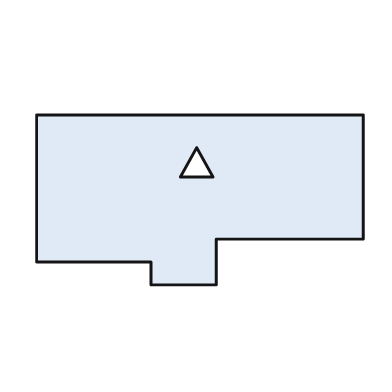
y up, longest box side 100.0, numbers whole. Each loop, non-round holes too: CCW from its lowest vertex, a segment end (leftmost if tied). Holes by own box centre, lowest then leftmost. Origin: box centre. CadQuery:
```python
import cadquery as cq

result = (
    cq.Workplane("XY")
    .moveTo(-15.0, -26.0)
    .lineTo(5.0, -26.0)
    .lineTo(5.0, -12.0)
    .lineTo(50.0, -12.0)
    .lineTo(50.0, 26.0)
    .lineTo(-50.0, 26.0)
    .lineTo(-50.0, -19.0)
    .lineTo(-15.0, -19.0)
    .close()
    .moveTo(-6.0, 7.0)
    .lineTo(4.0, 7.0)
    .lineTo(-1.0, 16.0)
    .close()
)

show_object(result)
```